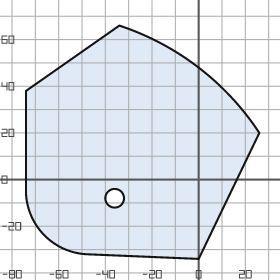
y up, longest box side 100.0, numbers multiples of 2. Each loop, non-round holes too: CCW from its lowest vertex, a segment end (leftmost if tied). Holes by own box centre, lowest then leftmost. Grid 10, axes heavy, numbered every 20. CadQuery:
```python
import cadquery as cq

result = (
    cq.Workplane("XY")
    .moveTo(0.0, -34.0)
    .lineTo(26.0, 20.0)
    .threePointArc((0.0, 48.0), (-34.0, 66.0))
    .lineTo(-74.0, 38.0)
    .lineTo(-74.0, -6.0)
    .threePointArc((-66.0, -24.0), (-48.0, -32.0))
    .close()
    .moveTo(-36.0, -8.0)
    .circle(4.0)
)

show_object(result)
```